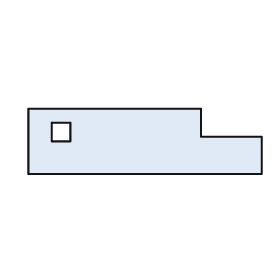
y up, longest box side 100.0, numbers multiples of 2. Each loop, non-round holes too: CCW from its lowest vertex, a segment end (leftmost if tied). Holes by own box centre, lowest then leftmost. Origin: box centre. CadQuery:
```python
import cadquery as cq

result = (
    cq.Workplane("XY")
    .moveTo(-50.0, -14.0)
    .lineTo(50.0, -14.0)
    .lineTo(50.0, 2.0)
    .lineTo(24.0, 2.0)
    .lineTo(24.0, 14.0)
    .lineTo(-50.0, 14.0)
    .close()
    .moveTo(-40.0, 0.0)
    .lineTo(-32.0, 0.0)
    .lineTo(-32.0, 8.0)
    .lineTo(-40.0, 8.0)
    .close()
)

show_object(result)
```